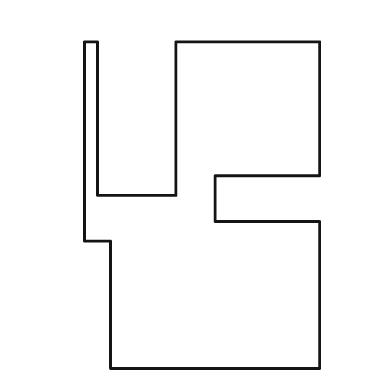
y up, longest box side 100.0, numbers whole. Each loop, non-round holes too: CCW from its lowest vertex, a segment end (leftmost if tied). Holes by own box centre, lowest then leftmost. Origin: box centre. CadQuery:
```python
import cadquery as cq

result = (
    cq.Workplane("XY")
    .moveTo(-28.0, -50.0)
    .lineTo(36.0, -50.0)
    .lineTo(36.0, -5.0)
    .lineTo(4.0, -5.0)
    .lineTo(4.0, 9.0)
    .lineTo(36.0, 9.0)
    .lineTo(36.0, 50.0)
    .lineTo(-8.0, 50.0)
    .lineTo(-8.0, 3.0)
    .lineTo(-32.0, 3.0)
    .lineTo(-32.0, 50.0)
    .lineTo(-36.0, 50.0)
    .lineTo(-36.0, -11.0)
    .lineTo(-28.0, -11.0)
    .close()
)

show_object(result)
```